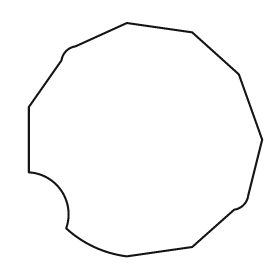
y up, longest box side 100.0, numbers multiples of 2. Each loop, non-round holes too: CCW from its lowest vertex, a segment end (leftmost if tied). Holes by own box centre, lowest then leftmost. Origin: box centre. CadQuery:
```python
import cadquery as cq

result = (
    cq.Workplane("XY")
    .moveTo(-8.0, -50.0)
    .lineTo(20.0, -46.0)
    .lineTo(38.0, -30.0)
    .threePointArc((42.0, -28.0), (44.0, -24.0))
    .lineTo(50.0, 0.0)
    .lineTo(40.0, 28.0)
    .lineTo(20.0, 46.0)
    .lineTo(-8.0, 50.0)
    .lineTo(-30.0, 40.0)
    .threePointArc((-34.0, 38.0), (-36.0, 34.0))
    .lineTo(-50.0, 14.0)
    .lineTo(-50.0, -14.0)
    .threePointArc((-36.0, -22.0), (-34.0, -38.0))
    .threePointArc((-22.0, -46.0), (-8.0, -50.0))
    .close()
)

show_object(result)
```